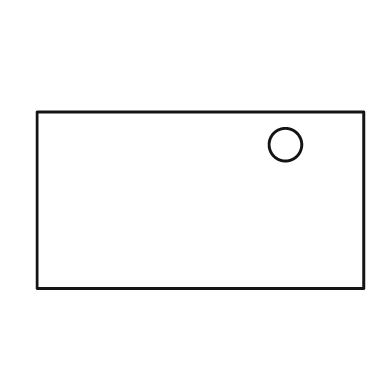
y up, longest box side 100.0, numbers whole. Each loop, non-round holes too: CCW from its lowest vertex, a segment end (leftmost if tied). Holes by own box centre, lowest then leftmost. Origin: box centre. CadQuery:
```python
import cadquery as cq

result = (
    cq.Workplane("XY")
    .moveTo(-50.0, -27.0)
    .lineTo(50.0, -27.0)
    .lineTo(50.0, 27.0)
    .lineTo(-50.0, 27.0)
    .close()
    .moveTo(26.0, 17.0)
    .circle(5.0)
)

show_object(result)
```